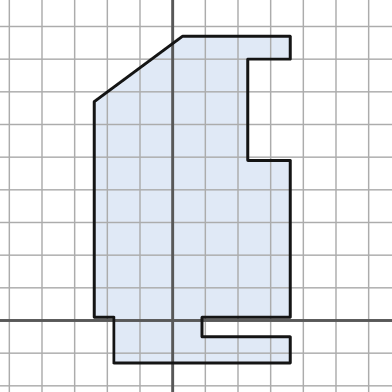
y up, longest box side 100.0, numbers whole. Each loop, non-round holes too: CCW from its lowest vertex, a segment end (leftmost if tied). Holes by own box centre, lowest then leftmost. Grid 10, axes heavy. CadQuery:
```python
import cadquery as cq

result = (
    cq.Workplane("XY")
    .moveTo(-18.0, -13.0)
    .lineTo(36.0, -13.0)
    .lineTo(36.0, -5.0)
    .lineTo(9.0, -5.0)
    .lineTo(9.0, 1.0)
    .lineTo(36.0, 1.0)
    .lineTo(36.0, 49.0)
    .lineTo(23.0, 49.0)
    .lineTo(23.0, 80.0)
    .lineTo(36.0, 80.0)
    .lineTo(36.0, 87.0)
    .lineTo(3.0, 87.0)
    .lineTo(-24.0, 67.0)
    .lineTo(-24.0, 1.0)
    .lineTo(-18.0, 1.0)
    .close()
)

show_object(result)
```